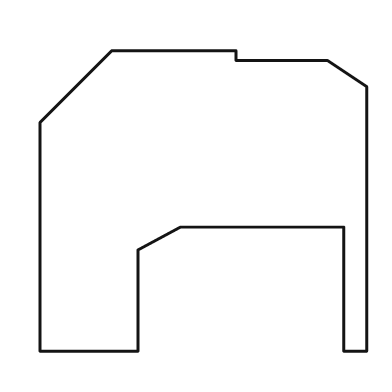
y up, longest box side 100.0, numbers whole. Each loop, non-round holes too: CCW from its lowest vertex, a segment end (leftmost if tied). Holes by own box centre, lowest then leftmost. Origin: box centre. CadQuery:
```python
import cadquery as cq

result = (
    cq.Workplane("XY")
    .moveTo(-50.0, -46.0)
    .lineTo(-20.0, -46.0)
    .lineTo(-20.0, -15.0)
    .lineTo(-7.0, -8.0)
    .lineTo(43.0, -8.0)
    .lineTo(43.0, -46.0)
    .lineTo(50.0, -46.0)
    .lineTo(50.0, 35.0)
    .lineTo(38.0, 43.0)
    .lineTo(10.0, 43.0)
    .lineTo(10.0, 46.0)
    .lineTo(-28.0, 46.0)
    .lineTo(-50.0, 24.0)
    .close()
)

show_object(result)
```